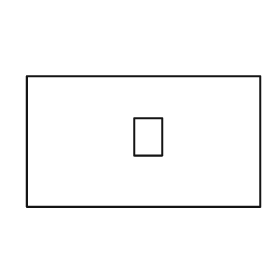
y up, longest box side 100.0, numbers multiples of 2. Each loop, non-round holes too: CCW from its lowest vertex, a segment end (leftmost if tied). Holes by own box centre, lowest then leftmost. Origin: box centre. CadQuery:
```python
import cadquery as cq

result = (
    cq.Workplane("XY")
    .moveTo(-50.0, -28.0)
    .lineTo(50.0, -28.0)
    .lineTo(50.0, 28.0)
    .lineTo(-50.0, 28.0)
    .close()
    .moveTo(-4.0, -6.0)
    .lineTo(8.0, -6.0)
    .lineTo(8.0, 10.0)
    .lineTo(-4.0, 10.0)
    .close()
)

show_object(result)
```